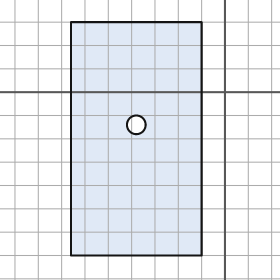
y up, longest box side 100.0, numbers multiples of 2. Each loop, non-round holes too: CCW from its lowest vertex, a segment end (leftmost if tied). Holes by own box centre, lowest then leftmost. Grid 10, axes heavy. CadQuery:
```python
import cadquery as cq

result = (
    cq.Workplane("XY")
    .moveTo(-66.0, -70.0)
    .lineTo(-10.0, -70.0)
    .lineTo(-10.0, 30.0)
    .lineTo(-66.0, 30.0)
    .close()
    .moveTo(-38.0, -14.0)
    .circle(4.0)
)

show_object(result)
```